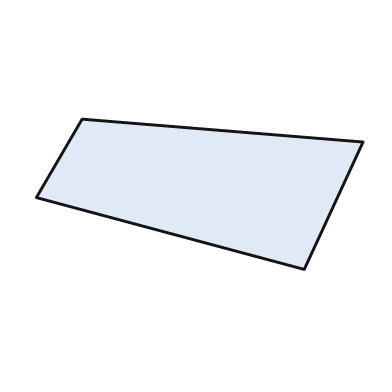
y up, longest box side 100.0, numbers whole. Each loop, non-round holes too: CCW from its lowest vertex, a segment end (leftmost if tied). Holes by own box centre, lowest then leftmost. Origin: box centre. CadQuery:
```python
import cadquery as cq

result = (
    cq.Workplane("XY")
    .moveTo(32.0, -23.0)
    .lineTo(50.0, 16.0)
    .lineTo(-36.0, 23.0)
    .lineTo(-50.0, -1.0)
    .close()
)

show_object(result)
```